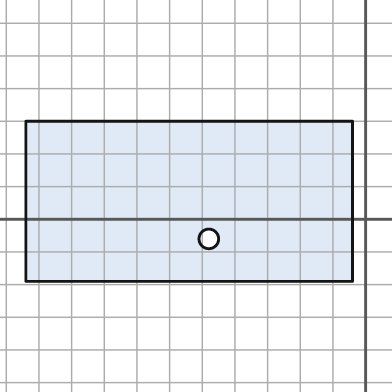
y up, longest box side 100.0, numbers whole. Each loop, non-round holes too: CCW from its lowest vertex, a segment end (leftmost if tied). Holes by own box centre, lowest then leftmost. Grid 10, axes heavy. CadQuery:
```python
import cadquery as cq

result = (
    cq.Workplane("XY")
    .moveTo(-104.0, -19.0)
    .lineTo(-4.0, -19.0)
    .lineTo(-4.0, 30.0)
    .lineTo(-104.0, 30.0)
    .close()
    .moveTo(-48.0, -6.0)
    .circle(3.0)
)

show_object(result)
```